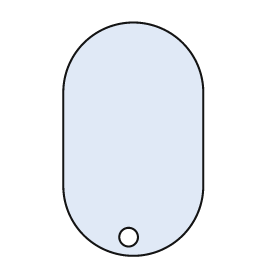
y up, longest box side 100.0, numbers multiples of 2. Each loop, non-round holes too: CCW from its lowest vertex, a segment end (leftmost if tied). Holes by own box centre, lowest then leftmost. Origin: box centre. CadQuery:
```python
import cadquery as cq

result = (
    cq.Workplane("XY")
    .moveTo(-30.0, -20.0)
    .threePointArc((0.0, -50.0), (30.0, -20.0))
    .lineTo(30.0, 20.0)
    .threePointArc((0.0, 50.0), (-30.0, 20.0))
    .close()
    .moveTo(-2.0, -42.0)
    .circle(4.0)
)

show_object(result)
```